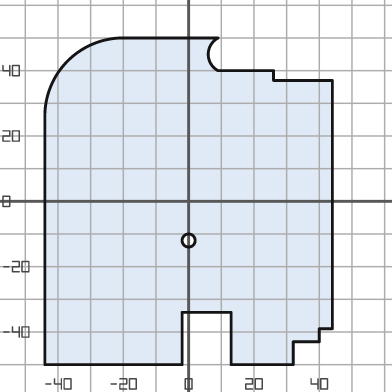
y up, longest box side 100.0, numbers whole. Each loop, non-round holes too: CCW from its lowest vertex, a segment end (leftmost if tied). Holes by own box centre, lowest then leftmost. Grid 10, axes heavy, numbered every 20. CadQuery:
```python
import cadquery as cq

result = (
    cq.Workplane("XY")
    .moveTo(-44.0, -50.0)
    .lineTo(-2.0, -50.0)
    .lineTo(-2.0, -34.0)
    .lineTo(13.0, -34.0)
    .lineTo(13.0, -50.0)
    .lineTo(32.0, -50.0)
    .lineTo(32.0, -43.0)
    .lineTo(40.0, -43.0)
    .lineTo(40.0, -39.0)
    .lineTo(44.0, -39.0)
    .lineTo(44.0, 37.0)
    .lineTo(26.0, 37.0)
    .lineTo(26.0, 40.0)
    .lineTo(9.0, 40.0)
    .threePointArc((6.0, 45.0), (9.0, 50.0))
    .lineTo(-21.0, 50.0)
    .threePointArc((-37.0, 43.0), (-44.0, 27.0))
    .close()
    .moveTo(0.0, -12.0)
    .circle(2.0)
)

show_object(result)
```